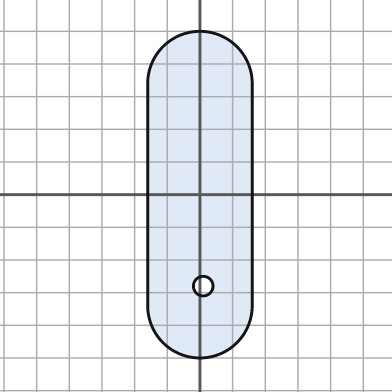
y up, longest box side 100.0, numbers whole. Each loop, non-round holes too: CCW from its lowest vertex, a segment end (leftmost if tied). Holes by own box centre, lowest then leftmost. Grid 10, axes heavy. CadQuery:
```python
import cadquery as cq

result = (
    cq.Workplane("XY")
    .moveTo(-16.0, -34.0)
    .threePointArc((0.0, -50.0), (16.0, -34.0))
    .lineTo(16.0, 34.0)
    .threePointArc((0.0, 50.0), (-16.0, 34.0))
    .close()
    .moveTo(1.0, -28.0)
    .circle(3.0)
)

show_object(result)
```